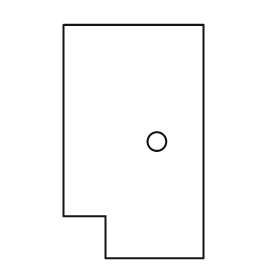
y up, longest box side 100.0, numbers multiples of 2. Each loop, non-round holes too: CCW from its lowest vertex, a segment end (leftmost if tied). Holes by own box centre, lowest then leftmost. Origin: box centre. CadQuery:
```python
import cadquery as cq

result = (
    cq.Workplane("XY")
    .moveTo(-12.0, -50.0)
    .lineTo(30.0, -50.0)
    .lineTo(30.0, 50.0)
    .lineTo(-30.0, 50.0)
    .lineTo(-30.0, -32.0)
    .lineTo(-12.0, -32.0)
    .close()
    .moveTo(10.0, 0.0)
    .circle(4.0)
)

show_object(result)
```